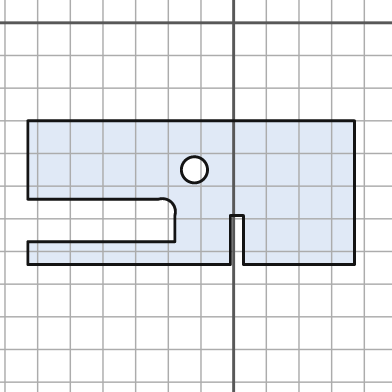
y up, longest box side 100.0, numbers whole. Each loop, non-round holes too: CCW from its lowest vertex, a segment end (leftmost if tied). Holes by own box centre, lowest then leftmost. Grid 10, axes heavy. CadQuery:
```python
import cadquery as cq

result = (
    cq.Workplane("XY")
    .moveTo(-63.0, -74.0)
    .lineTo(-1.0, -74.0)
    .lineTo(-1.0, -59.0)
    .lineTo(3.0, -59.0)
    .lineTo(3.0, -74.0)
    .lineTo(37.0, -74.0)
    .lineTo(37.0, -30.0)
    .lineTo(-63.0, -30.0)
    .lineTo(-63.0, -54.0)
    .lineTo(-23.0, -54.0)
    .threePointArc((-19.0, -55.0), (-18.0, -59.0))
    .lineTo(-18.0, -67.0)
    .lineTo(-63.0, -67.0)
    .close()
    .moveTo(-12.0, -45.0)
    .circle(4.0)
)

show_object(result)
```